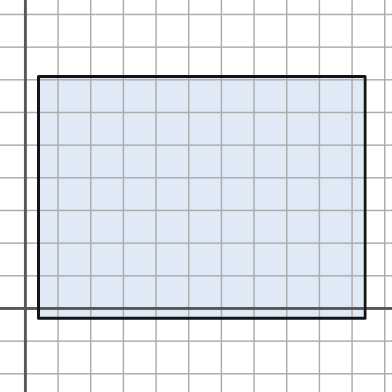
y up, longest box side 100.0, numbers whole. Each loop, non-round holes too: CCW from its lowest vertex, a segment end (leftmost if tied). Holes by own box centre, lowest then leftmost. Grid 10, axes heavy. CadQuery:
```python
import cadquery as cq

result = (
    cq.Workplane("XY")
    .moveTo(4.0, -3.0)
    .lineTo(104.0, -3.0)
    .lineTo(104.0, 71.0)
    .lineTo(4.0, 71.0)
    .close()
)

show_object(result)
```